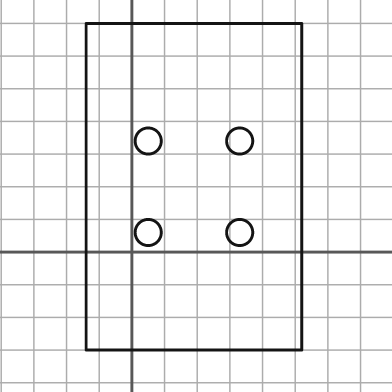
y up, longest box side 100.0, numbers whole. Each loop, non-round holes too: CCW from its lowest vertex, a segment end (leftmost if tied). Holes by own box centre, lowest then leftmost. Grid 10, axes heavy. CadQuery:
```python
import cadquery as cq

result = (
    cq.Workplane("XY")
    .moveTo(-14.0, -30.0)
    .lineTo(52.0, -30.0)
    .lineTo(52.0, 70.0)
    .lineTo(-14.0, 70.0)
    .close()
    .moveTo(5.0, 6.0)
    .circle(4.0)
    .moveTo(33.0, 6.0)
    .circle(4.0)
    .moveTo(5.0, 34.0)
    .circle(4.0)
    .moveTo(33.0, 34.0)
    .circle(4.0)
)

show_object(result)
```